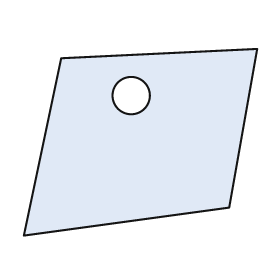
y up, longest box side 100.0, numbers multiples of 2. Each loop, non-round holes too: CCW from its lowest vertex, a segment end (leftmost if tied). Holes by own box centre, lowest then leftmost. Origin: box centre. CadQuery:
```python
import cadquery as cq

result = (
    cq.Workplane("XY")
    .moveTo(-50.0, -40.0)
    .lineTo(38.0, -28.0)
    .lineTo(50.0, 40.0)
    .lineTo(-34.0, 36.0)
    .close()
    .moveTo(-4.0, 20.0)
    .circle(8.0)
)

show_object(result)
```